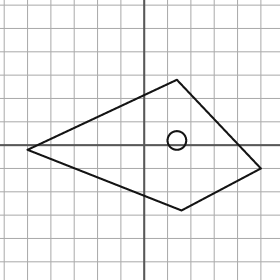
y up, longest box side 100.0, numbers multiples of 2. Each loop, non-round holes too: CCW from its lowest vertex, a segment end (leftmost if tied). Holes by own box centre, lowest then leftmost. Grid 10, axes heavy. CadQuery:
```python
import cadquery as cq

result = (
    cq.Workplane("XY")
    .moveTo(16.0, -28.0)
    .lineTo(50.0, -10.0)
    .lineTo(14.0, 28.0)
    .lineTo(-50.0, -2.0)
    .close()
    .moveTo(14.0, 2.0)
    .circle(4.0)
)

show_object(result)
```